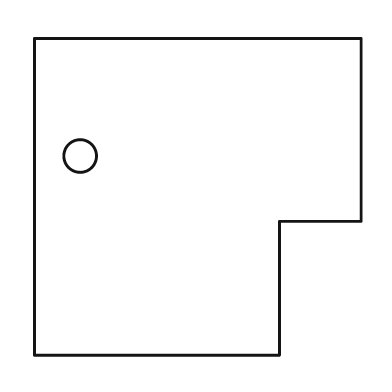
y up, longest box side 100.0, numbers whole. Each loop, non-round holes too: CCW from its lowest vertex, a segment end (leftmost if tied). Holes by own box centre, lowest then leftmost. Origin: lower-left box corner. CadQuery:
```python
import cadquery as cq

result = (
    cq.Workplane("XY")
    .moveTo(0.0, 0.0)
    .lineTo(75.0, 0.0)
    .lineTo(75.0, 41.0)
    .lineTo(100.0, 41.0)
    .lineTo(100.0, 97.0)
    .lineTo(0.0, 97.0)
    .close()
    .moveTo(14.0, 61.0)
    .circle(5.0)
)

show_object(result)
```